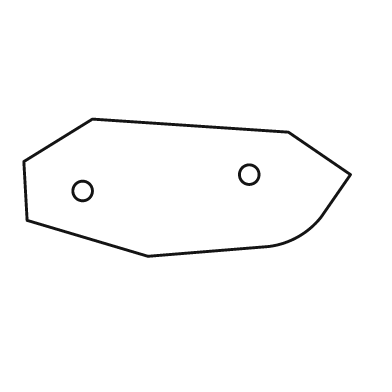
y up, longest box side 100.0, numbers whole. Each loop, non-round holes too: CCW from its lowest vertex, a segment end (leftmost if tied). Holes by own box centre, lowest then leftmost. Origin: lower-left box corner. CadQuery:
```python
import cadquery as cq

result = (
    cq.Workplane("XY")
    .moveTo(38.0, 0.0)
    .lineTo(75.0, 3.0)
    .threePointArc((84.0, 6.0), (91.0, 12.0))
    .lineTo(100.0, 25.0)
    .lineTo(81.0, 38.0)
    .lineTo(21.0, 42.0)
    .lineTo(0.0, 29.0)
    .lineTo(1.0, 11.0)
    .close()
    .moveTo(18.0, 20.0)
    .circle(3.0)
    .moveTo(69.0, 25.0)
    .circle(3.0)
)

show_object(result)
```